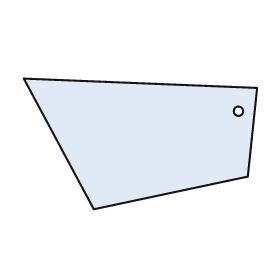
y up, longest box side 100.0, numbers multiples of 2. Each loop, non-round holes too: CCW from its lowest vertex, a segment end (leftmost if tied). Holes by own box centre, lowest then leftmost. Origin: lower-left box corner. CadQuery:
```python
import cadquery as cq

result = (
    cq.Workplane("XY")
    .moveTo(30.0, 0.0)
    .lineTo(96.0, 14.0)
    .lineTo(100.0, 52.0)
    .lineTo(0.0, 56.0)
    .close()
    .moveTo(92.0, 42.0)
    .circle(2.0)
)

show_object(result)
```